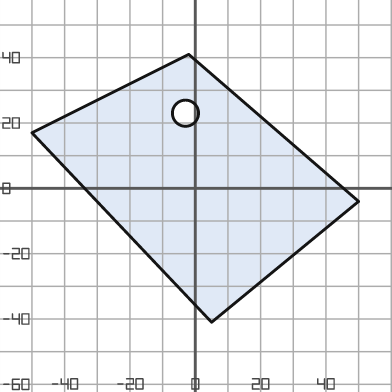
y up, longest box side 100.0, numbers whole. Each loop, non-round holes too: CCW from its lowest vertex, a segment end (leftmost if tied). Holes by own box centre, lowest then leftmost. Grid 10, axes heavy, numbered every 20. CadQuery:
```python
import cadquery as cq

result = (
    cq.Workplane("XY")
    .moveTo(5.0, -41.0)
    .lineTo(50.0, -4.0)
    .lineTo(-2.0, 41.0)
    .lineTo(-50.0, 17.0)
    .close()
    .moveTo(-3.0, 23.0)
    .circle(4.0)
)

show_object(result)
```